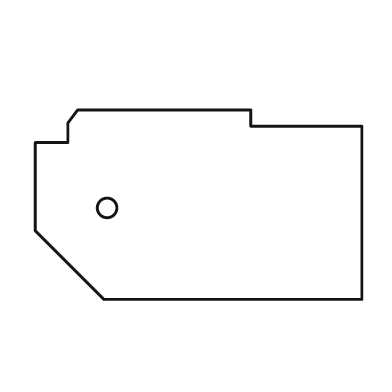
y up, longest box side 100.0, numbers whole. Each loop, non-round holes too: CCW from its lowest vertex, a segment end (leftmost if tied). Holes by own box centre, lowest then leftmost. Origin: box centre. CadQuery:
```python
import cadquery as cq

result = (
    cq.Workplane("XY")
    .moveTo(-29.0, -29.0)
    .lineTo(50.0, -29.0)
    .lineTo(50.0, 24.0)
    .lineTo(16.0, 24.0)
    .lineTo(16.0, 29.0)
    .lineTo(-37.0, 29.0)
    .lineTo(-40.0, 25.0)
    .lineTo(-40.0, 19.0)
    .lineTo(-50.0, 19.0)
    .lineTo(-50.0, -8.0)
    .close()
    .moveTo(-28.0, -1.0)
    .circle(3.0)
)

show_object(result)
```